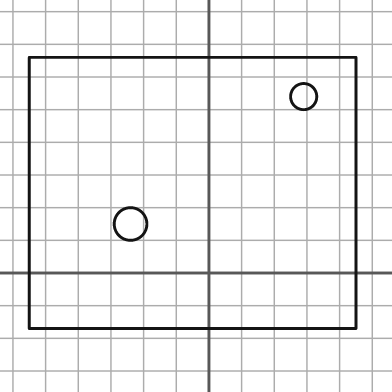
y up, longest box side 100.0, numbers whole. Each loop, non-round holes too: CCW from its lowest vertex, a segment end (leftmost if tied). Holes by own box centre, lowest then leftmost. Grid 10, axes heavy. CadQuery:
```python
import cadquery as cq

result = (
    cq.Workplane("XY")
    .moveTo(-55.0, -17.0)
    .lineTo(45.0, -17.0)
    .lineTo(45.0, 66.0)
    .lineTo(-55.0, 66.0)
    .close()
    .moveTo(-24.0, 15.0)
    .circle(5.0)
    .moveTo(29.0, 54.0)
    .circle(4.0)
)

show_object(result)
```